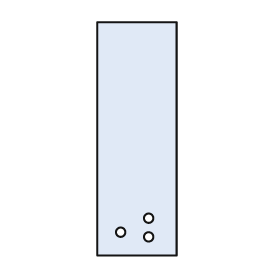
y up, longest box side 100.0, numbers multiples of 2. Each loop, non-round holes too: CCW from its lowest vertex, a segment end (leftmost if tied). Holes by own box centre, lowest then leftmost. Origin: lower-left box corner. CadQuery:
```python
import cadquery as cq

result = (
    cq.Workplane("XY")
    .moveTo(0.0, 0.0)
    .lineTo(34.0, 0.0)
    .lineTo(34.0, 100.0)
    .lineTo(0.0, 100.0)
    .close()
    .moveTo(22.0, 8.0)
    .circle(2.0)
    .moveTo(10.0, 10.0)
    .circle(2.0)
    .moveTo(22.0, 16.0)
    .circle(2.0)
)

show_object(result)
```